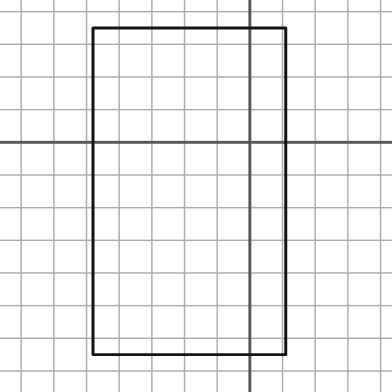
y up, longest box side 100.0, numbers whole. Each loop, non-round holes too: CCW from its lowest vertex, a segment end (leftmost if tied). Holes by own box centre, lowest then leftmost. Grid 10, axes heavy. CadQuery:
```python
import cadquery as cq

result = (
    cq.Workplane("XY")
    .moveTo(-48.0, -65.0)
    .lineTo(11.0, -65.0)
    .lineTo(11.0, 35.0)
    .lineTo(-48.0, 35.0)
    .close()
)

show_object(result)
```